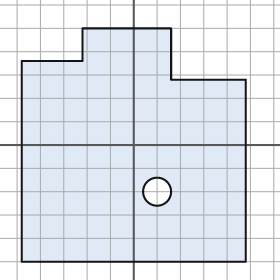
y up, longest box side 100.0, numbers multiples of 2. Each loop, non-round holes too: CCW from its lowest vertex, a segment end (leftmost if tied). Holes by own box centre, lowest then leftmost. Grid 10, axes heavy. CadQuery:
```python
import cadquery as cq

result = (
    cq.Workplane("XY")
    .moveTo(-48.0, -50.0)
    .lineTo(48.0, -50.0)
    .lineTo(48.0, 28.0)
    .lineTo(16.0, 28.0)
    .lineTo(16.0, 50.0)
    .lineTo(-22.0, 50.0)
    .lineTo(-22.0, 36.0)
    .lineTo(-48.0, 36.0)
    .close()
    .moveTo(10.0, -20.0)
    .circle(6.0)
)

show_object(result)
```